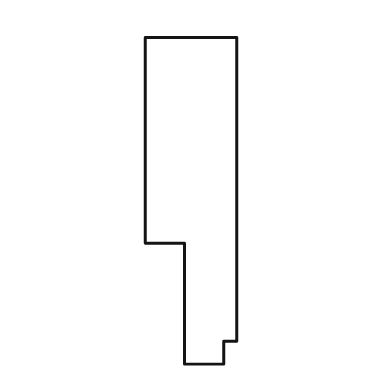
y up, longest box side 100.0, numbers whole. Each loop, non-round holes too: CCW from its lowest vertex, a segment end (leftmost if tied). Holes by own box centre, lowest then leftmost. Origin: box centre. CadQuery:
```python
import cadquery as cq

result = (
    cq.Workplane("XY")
    .moveTo(-2.0, -50.0)
    .lineTo(10.0, -50.0)
    .lineTo(10.0, -43.0)
    .lineTo(14.0, -43.0)
    .lineTo(14.0, 50.0)
    .lineTo(-14.0, 50.0)
    .lineTo(-14.0, -13.0)
    .lineTo(-2.0, -13.0)
    .close()
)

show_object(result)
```